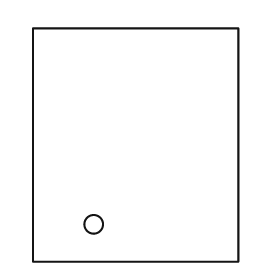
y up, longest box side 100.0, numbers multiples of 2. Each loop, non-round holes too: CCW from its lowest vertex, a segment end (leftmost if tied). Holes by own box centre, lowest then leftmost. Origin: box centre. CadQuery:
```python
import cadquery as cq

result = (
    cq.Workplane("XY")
    .moveTo(-44.0, -50.0)
    .lineTo(44.0, -50.0)
    .lineTo(44.0, 50.0)
    .lineTo(-44.0, 50.0)
    .close()
    .moveTo(-18.0, -34.0)
    .circle(4.0)
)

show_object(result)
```